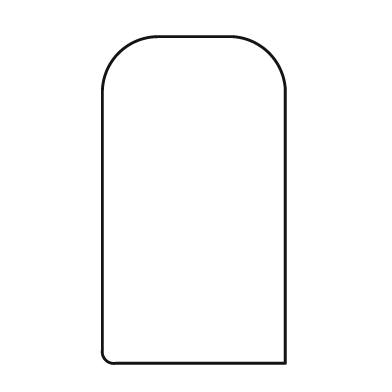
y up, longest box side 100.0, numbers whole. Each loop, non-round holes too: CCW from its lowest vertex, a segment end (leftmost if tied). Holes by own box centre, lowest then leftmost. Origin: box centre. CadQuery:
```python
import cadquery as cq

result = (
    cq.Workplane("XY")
    .moveTo(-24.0, -50.0)
    .lineTo(28.0, -50.0)
    .lineTo(28.0, 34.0)
    .threePointArc((23.0, 45.0), (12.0, 50.0))
    .lineTo(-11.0, 50.0)
    .threePointArc((-23.0, 45.0), (-28.0, 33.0))
    .lineTo(-28.0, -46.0)
    .threePointArc((-27.0, -49.0), (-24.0, -50.0))
    .close()
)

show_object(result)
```